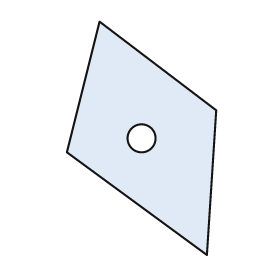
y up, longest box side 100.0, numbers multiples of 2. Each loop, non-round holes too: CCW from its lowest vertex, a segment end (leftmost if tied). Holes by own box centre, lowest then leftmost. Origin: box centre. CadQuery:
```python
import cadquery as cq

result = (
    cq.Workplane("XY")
    .moveTo(28.0, -50.0)
    .lineTo(32.0, 12.0)
    .lineTo(-18.0, 50.0)
    .lineTo(-32.0, -6.0)
    .close()
    .moveTo(0.0, 0.0)
    .circle(6.0)
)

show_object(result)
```